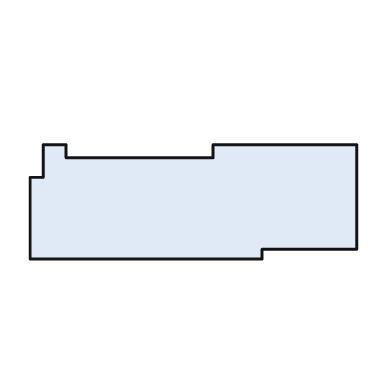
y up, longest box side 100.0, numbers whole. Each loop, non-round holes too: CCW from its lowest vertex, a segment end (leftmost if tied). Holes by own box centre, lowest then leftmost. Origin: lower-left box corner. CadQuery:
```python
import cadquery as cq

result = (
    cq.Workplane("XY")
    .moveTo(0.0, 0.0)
    .lineTo(71.0, 0.0)
    .lineTo(71.0, 3.0)
    .lineTo(100.0, 3.0)
    .lineTo(100.0, 35.0)
    .lineTo(56.0, 35.0)
    .lineTo(56.0, 31.0)
    .lineTo(11.0, 31.0)
    .lineTo(11.0, 35.0)
    .lineTo(4.0, 35.0)
    .lineTo(4.0, 25.0)
    .lineTo(0.0, 25.0)
    .close()
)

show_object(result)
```